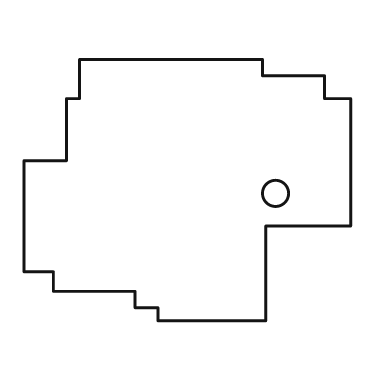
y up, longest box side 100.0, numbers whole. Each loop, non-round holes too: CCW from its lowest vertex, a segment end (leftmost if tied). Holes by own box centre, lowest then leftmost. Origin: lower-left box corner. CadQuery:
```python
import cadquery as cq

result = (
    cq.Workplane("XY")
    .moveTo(41.0, 0.0)
    .lineTo(74.0, 0.0)
    .lineTo(74.0, 29.0)
    .lineTo(100.0, 29.0)
    .lineTo(100.0, 68.0)
    .lineTo(92.0, 68.0)
    .lineTo(92.0, 75.0)
    .lineTo(73.0, 75.0)
    .lineTo(73.0, 80.0)
    .lineTo(17.0, 80.0)
    .lineTo(17.0, 68.0)
    .lineTo(13.0, 68.0)
    .lineTo(13.0, 49.0)
    .lineTo(0.0, 49.0)
    .lineTo(0.0, 15.0)
    .lineTo(9.0, 15.0)
    .lineTo(9.0, 9.0)
    .lineTo(34.0, 9.0)
    .lineTo(34.0, 4.0)
    .lineTo(41.0, 4.0)
    .close()
    .moveTo(77.0, 39.0)
    .circle(4.0)
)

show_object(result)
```